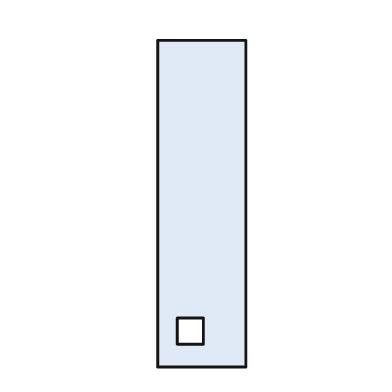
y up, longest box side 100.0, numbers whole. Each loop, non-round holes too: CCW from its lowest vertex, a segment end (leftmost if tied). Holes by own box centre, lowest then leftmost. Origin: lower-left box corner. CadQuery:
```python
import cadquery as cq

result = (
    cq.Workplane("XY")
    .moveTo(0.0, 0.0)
    .lineTo(27.0, 0.0)
    .lineTo(27.0, 100.0)
    .lineTo(0.0, 100.0)
    .close()
    .moveTo(6.0, 7.0)
    .lineTo(14.0, 7.0)
    .lineTo(14.0, 15.0)
    .lineTo(6.0, 15.0)
    .close()
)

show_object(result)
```